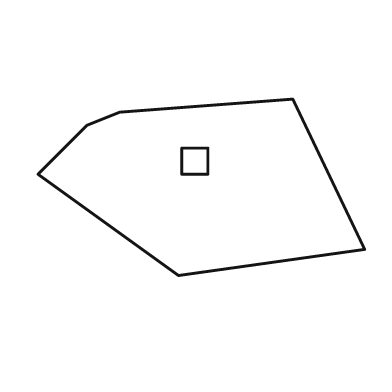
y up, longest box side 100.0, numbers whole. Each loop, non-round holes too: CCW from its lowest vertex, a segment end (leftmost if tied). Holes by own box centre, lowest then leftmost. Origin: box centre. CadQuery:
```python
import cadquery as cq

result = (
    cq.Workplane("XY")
    .moveTo(-7.0, -27.0)
    .lineTo(50.0, -19.0)
    .lineTo(28.0, 27.0)
    .lineTo(-25.0, 23.0)
    .lineTo(-35.0, 19.0)
    .lineTo(-50.0, 4.0)
    .close()
    .moveTo(-6.0, 4.0)
    .lineTo(2.0, 4.0)
    .lineTo(2.0, 12.0)
    .lineTo(-6.0, 12.0)
    .close()
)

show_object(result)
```